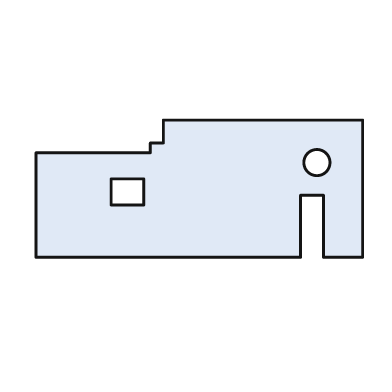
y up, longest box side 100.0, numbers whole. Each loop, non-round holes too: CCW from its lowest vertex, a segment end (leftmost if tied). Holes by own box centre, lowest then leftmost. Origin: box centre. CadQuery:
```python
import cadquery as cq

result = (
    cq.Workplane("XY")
    .moveTo(-50.0, -21.0)
    .lineTo(31.0, -21.0)
    .lineTo(31.0, -2.0)
    .lineTo(38.0, -2.0)
    .lineTo(38.0, -21.0)
    .lineTo(50.0, -21.0)
    .lineTo(50.0, 21.0)
    .lineTo(-11.0, 21.0)
    .lineTo(-11.0, 14.0)
    .lineTo(-15.0, 14.0)
    .lineTo(-15.0, 11.0)
    .lineTo(-50.0, 11.0)
    .close()
    .moveTo(-27.0, -5.0)
    .lineTo(-17.0, -5.0)
    .lineTo(-17.0, 3.0)
    .lineTo(-27.0, 3.0)
    .close()
    .moveTo(36.0, 8.0)
    .circle(4.0)
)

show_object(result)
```